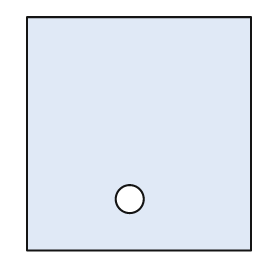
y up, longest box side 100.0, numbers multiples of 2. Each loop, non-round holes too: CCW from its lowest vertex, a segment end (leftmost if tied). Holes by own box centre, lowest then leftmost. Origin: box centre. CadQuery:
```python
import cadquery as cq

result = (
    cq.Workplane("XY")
    .moveTo(-48.0, -50.0)
    .lineTo(48.0, -50.0)
    .lineTo(48.0, 50.0)
    .lineTo(-48.0, 50.0)
    .close()
    .moveTo(-4.0, -28.0)
    .circle(6.0)
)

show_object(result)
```